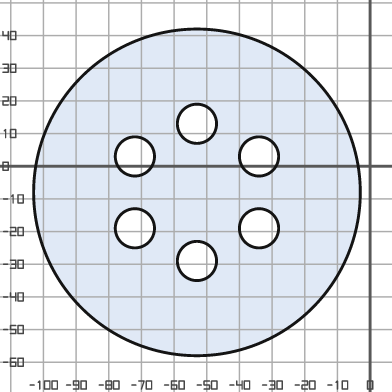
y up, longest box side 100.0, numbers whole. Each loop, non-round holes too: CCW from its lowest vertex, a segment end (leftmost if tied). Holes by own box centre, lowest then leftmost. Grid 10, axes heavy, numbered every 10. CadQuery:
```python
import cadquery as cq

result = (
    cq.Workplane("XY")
    .moveTo(-53.0, -8.0)
    .circle(50.0)
    .moveTo(-53.0, -29.0)
    .circle(6.0)
    .moveTo(-72.0, -19.0)
    .circle(6.0)
    .moveTo(-34.0, -19.0)
    .circle(6.0)
    .moveTo(-72.0, 3.0)
    .circle(6.0)
    .moveTo(-34.0, 3.0)
    .circle(6.0)
    .moveTo(-53.0, 13.0)
    .circle(6.0)
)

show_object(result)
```